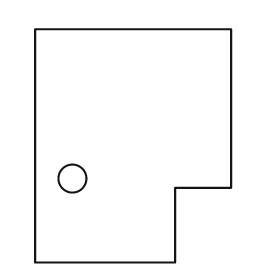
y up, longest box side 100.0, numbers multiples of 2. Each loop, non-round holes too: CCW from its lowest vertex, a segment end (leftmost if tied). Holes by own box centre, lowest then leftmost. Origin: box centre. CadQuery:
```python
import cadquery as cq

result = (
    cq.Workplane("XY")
    .moveTo(-42.0, -50.0)
    .lineTo(18.0, -50.0)
    .lineTo(18.0, -18.0)
    .lineTo(42.0, -18.0)
    .lineTo(42.0, 50.0)
    .lineTo(-42.0, 50.0)
    .close()
    .moveTo(-26.0, -14.0)
    .circle(6.0)
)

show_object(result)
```